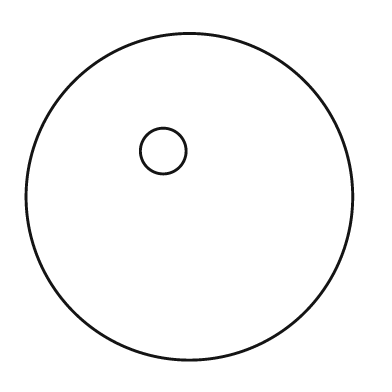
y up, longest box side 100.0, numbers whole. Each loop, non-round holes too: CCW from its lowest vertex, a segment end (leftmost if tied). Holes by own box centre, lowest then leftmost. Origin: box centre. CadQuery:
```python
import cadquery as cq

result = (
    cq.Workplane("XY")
    .moveTo(0.0, 0.0)
    .circle(50.0)
    .moveTo(-8.0, 14.0)
    .circle(7.0)
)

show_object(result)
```